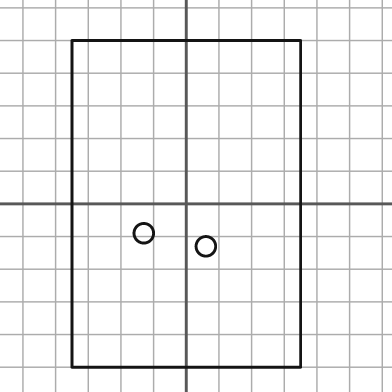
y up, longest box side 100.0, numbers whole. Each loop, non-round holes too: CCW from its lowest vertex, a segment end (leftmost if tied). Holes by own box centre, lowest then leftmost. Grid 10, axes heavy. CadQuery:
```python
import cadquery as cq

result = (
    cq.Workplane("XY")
    .moveTo(-35.0, -50.0)
    .lineTo(35.0, -50.0)
    .lineTo(35.0, 50.0)
    .lineTo(-35.0, 50.0)
    .close()
    .moveTo(6.0, -13.0)
    .circle(3.0)
    .moveTo(-13.0, -9.0)
    .circle(3.0)
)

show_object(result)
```